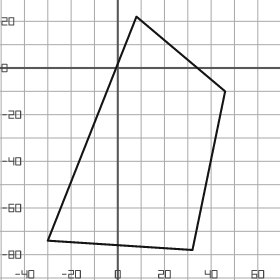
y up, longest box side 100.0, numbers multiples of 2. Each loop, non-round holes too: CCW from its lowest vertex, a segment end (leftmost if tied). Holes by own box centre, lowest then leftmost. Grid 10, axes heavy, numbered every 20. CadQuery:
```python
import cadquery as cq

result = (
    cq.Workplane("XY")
    .moveTo(32.0, -78.0)
    .lineTo(46.0, -10.0)
    .lineTo(8.0, 22.0)
    .lineTo(-30.0, -74.0)
    .close()
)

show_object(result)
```